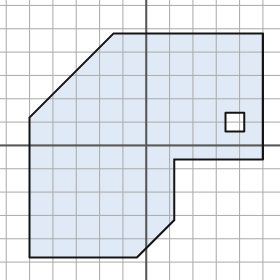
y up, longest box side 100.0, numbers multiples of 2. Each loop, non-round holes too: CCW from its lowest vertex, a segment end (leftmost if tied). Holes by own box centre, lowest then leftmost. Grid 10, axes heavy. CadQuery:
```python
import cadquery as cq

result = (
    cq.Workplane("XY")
    .moveTo(-50.0, -48.0)
    .lineTo(-4.0, -48.0)
    .lineTo(12.0, -32.0)
    .lineTo(12.0, -6.0)
    .lineTo(50.0, -6.0)
    .lineTo(50.0, 48.0)
    .lineTo(-14.0, 48.0)
    .lineTo(-50.0, 12.0)
    .close()
    .moveTo(34.0, 6.0)
    .lineTo(42.0, 6.0)
    .lineTo(42.0, 14.0)
    .lineTo(34.0, 14.0)
    .close()
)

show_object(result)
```